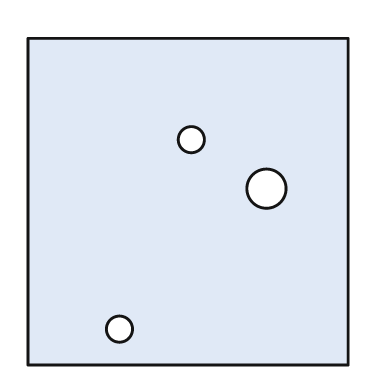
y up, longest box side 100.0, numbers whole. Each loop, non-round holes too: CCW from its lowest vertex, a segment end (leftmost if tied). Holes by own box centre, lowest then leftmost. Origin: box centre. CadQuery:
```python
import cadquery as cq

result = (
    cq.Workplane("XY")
    .moveTo(-49.0, -50.0)
    .lineTo(49.0, -50.0)
    .lineTo(49.0, 50.0)
    .lineTo(-49.0, 50.0)
    .close()
    .moveTo(-21.0, -39.0)
    .circle(4.0)
    .moveTo(24.0, 4.0)
    .circle(6.0)
    .moveTo(1.0, 19.0)
    .circle(4.0)
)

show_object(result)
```